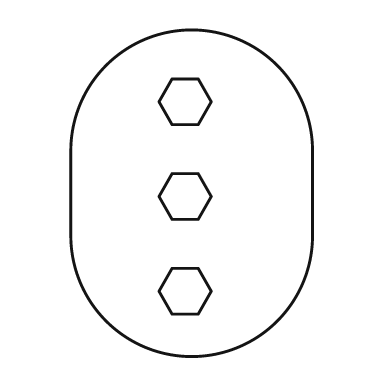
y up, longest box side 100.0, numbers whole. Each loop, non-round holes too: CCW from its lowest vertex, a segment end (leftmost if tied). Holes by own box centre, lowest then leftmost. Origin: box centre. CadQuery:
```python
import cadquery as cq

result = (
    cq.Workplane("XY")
    .moveTo(-37.0, -13.0)
    .threePointArc((0.0, -50.0), (37.0, -13.0))
    .lineTo(37.0, 13.0)
    .threePointArc((0.0, 50.0), (-37.0, 13.0))
    .close()
    .moveTo(-6.0, -37.0)
    .lineTo(2.0, -37.0)
    .lineTo(6.0, -30.0)
    .lineTo(2.0, -23.0)
    .lineTo(-6.0, -23.0)
    .lineTo(-10.0, -30.0)
    .close()
    .moveTo(-6.0, -8.0)
    .lineTo(2.0, -8.0)
    .lineTo(6.0, -1.0)
    .lineTo(2.0, 6.0)
    .lineTo(-6.0, 6.0)
    .lineTo(-10.0, -1.0)
    .close()
    .moveTo(-6.0, 21.0)
    .lineTo(2.0, 21.0)
    .lineTo(6.0, 28.0)
    .lineTo(2.0, 35.0)
    .lineTo(-6.0, 35.0)
    .lineTo(-10.0, 28.0)
    .close()
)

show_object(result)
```